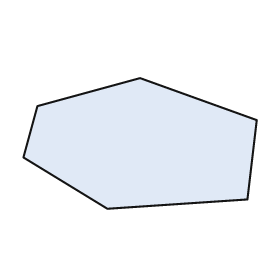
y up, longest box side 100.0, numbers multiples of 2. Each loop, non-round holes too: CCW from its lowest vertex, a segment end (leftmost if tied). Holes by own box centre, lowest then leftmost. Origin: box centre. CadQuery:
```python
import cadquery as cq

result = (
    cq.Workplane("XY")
    .moveTo(-14.0, -28.0)
    .lineTo(46.0, -24.0)
    .lineTo(50.0, 10.0)
    .lineTo(0.0, 28.0)
    .lineTo(-44.0, 16.0)
    .lineTo(-50.0, -6.0)
    .close()
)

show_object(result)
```